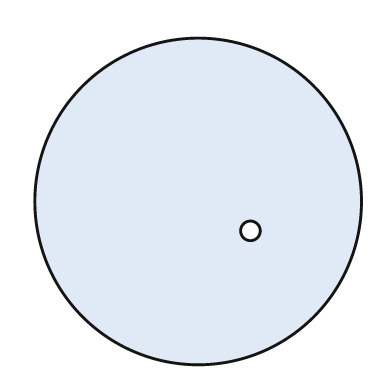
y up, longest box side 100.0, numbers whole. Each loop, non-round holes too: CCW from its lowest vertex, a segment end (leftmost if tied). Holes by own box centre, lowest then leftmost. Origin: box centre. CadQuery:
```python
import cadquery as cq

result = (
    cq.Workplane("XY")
    .moveTo(0.0, 0.0)
    .circle(50.0)
    .moveTo(16.0, -9.0)
    .circle(3.0)
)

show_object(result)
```